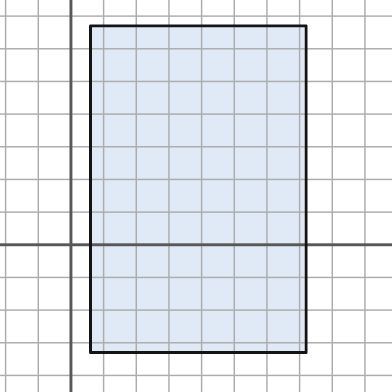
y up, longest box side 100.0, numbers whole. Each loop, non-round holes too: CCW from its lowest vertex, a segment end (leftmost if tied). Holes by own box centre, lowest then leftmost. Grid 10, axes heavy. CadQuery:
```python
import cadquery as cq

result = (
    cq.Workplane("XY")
    .moveTo(6.0, -33.0)
    .lineTo(72.0, -33.0)
    .lineTo(72.0, 67.0)
    .lineTo(6.0, 67.0)
    .close()
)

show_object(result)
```